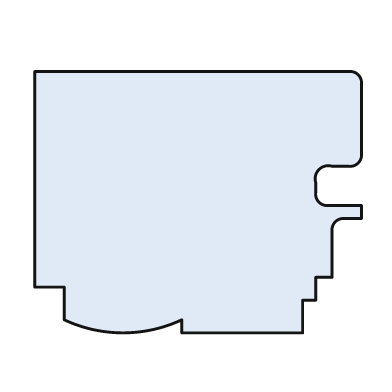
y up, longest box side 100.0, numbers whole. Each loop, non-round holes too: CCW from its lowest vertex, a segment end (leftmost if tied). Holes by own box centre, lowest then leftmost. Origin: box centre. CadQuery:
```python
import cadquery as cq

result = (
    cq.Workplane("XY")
    .moveTo(-5.0, -40.0)
    .lineTo(32.0, -40.0)
    .lineTo(32.0, -30.0)
    .lineTo(36.0, -30.0)
    .lineTo(36.0, -23.0)
    .lineTo(41.0, -23.0)
    .lineTo(41.0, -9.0)
    .threePointArc((42.0, -6.0), (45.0, -5.0))
    .lineTo(50.0, -5.0)
    .lineTo(50.0, -1.0)
    .lineTo(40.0, -1.0)
    .threePointArc((37.0, 0.0), (36.0, 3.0))
    .lineTo(36.0, 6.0)
    .threePointArc((37.0, 10.0), (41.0, 11.0))
    .lineTo(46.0, 11.0)
    .threePointArc((49.0, 12.0), (50.0, 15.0))
    .lineTo(50.0, 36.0)
    .threePointArc((49.0, 39.0), (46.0, 40.0))
    .lineTo(-50.0, 40.0)
    .lineTo(-50.0, -26.0)
    .lineTo(-41.0, -26.0)
    .lineTo(-41.0, -36.0)
    .threePointArc((-23.0, -40.0), (-5.0, -36.0))
    .close()
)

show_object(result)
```